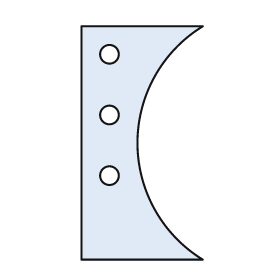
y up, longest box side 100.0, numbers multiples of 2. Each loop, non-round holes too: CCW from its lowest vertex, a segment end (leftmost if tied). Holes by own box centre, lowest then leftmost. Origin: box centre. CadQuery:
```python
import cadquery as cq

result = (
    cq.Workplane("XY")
    .moveTo(-26.0, -50.0)
    .lineTo(26.0, -50.0)
    .threePointArc((-2.0, 0.0), (26.0, 50.0))
    .lineTo(-26.0, 50.0)
    .close()
    .moveTo(-14.0, -14.0)
    .circle(4.0)
    .moveTo(-14.0, 12.0)
    .circle(4.0)
    .moveTo(-14.0, 38.0)
    .circle(4.0)
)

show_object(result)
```